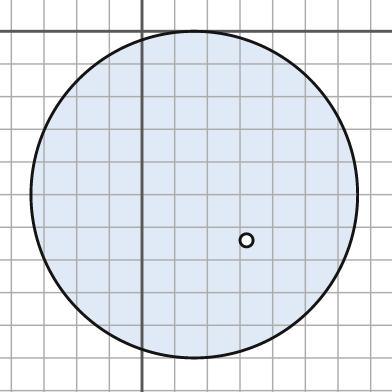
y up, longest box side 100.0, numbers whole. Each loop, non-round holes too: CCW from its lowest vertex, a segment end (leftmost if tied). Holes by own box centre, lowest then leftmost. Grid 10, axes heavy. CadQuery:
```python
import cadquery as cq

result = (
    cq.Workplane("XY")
    .moveTo(16.0, -50.0)
    .circle(50.0)
    .moveTo(32.0, -64.0)
    .circle(2.0)
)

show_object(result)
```